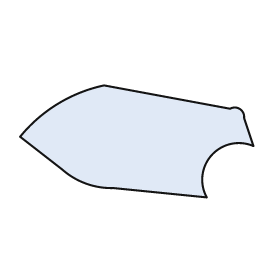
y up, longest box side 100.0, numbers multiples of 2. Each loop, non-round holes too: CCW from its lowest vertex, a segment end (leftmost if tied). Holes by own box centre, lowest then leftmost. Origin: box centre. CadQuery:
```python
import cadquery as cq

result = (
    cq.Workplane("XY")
    .moveTo(30.0, -24.0)
    .threePointArc((32.0, -6.0), (50.0, -2.0))
    .lineTo(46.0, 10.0)
    .threePointArc((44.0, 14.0), (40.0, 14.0))
    .lineTo(-14.0, 24.0)
    .threePointArc((-34.0, 16.0), (-50.0, 2.0))
    .lineTo(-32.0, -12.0)
    .threePointArc((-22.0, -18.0), (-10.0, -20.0))
    .close()
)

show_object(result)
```